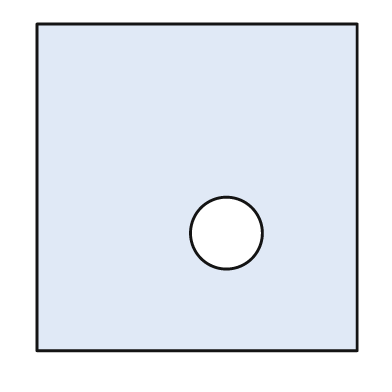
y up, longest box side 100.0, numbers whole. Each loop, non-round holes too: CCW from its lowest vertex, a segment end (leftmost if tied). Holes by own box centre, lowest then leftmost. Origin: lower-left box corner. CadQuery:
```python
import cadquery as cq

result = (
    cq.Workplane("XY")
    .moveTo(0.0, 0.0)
    .lineTo(98.0, 0.0)
    .lineTo(98.0, 100.0)
    .lineTo(0.0, 100.0)
    .close()
    .moveTo(58.0, 36.0)
    .circle(11.0)
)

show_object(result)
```